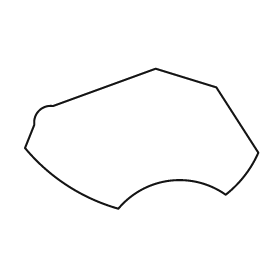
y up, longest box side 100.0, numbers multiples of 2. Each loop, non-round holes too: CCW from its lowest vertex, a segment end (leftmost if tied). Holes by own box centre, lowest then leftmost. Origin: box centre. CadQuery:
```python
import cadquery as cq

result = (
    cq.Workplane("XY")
    .moveTo(-10.0, -30.0)
    .threePointArc((12.0, -18.0), (36.0, -24.0))
    .threePointArc((44.0, -16.0), (50.0, -6.0))
    .lineTo(32.0, 22.0)
    .lineTo(6.0, 30.0)
    .lineTo(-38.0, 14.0)
    .threePointArc((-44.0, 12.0), (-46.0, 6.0))
    .lineTo(-50.0, -4.0)
    .threePointArc((-32.0, -20.0), (-10.0, -30.0))
    .close()
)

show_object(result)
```